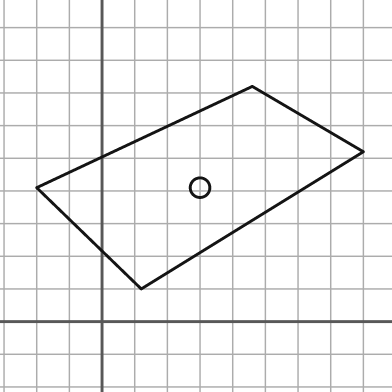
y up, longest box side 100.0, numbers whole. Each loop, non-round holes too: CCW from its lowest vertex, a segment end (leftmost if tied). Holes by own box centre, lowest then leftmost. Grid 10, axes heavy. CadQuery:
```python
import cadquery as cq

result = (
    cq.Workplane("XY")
    .moveTo(12.0, 10.0)
    .lineTo(80.0, 52.0)
    .lineTo(46.0, 72.0)
    .lineTo(-20.0, 41.0)
    .close()
    .moveTo(30.0, 41.0)
    .circle(3.0)
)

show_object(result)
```